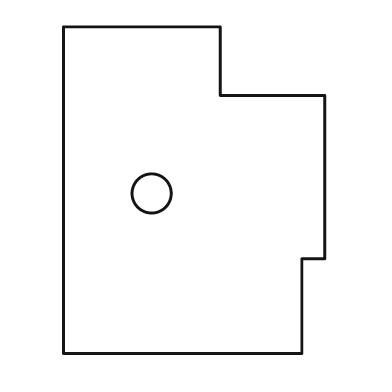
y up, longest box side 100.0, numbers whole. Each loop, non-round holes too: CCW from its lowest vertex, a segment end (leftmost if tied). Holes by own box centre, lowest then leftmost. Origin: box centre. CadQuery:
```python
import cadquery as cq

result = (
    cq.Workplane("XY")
    .moveTo(-40.0, -50.0)
    .lineTo(33.0, -50.0)
    .lineTo(33.0, -21.0)
    .lineTo(40.0, -21.0)
    .lineTo(40.0, 29.0)
    .lineTo(8.0, 29.0)
    .lineTo(8.0, 50.0)
    .lineTo(-40.0, 50.0)
    .close()
    .moveTo(-13.0, -1.0)
    .circle(6.0)
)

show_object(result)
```